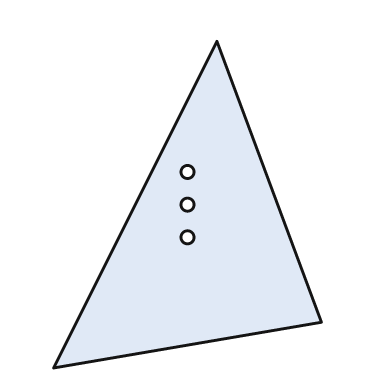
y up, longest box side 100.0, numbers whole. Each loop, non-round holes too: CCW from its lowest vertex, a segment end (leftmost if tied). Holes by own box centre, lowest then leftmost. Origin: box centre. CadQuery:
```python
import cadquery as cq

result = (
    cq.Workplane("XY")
    .moveTo(-41.0, -50.0)
    .lineTo(41.0, -36.0)
    .lineTo(9.0, 50.0)
    .close()
    .moveTo(0.0, -10.0)
    .circle(2.0)
    .moveTo(0.0, 0.0)
    .circle(2.0)
    .moveTo(0.0, 10.0)
    .circle(2.0)
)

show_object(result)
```